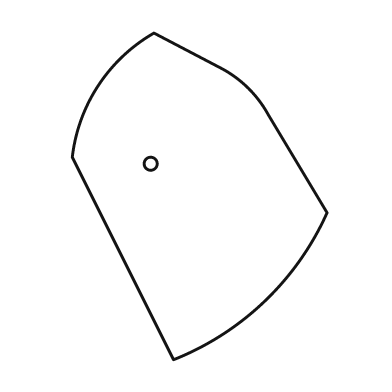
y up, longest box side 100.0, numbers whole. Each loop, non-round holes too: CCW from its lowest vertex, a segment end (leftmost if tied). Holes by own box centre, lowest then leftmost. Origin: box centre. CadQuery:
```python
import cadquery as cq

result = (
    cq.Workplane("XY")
    .moveTo(-8.0, -50.0)
    .threePointArc((20.0, -32.0), (39.0, -5.0))
    .lineTo(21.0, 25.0)
    .threePointArc((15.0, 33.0), (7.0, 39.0))
    .lineTo(-14.0, 50.0)
    .threePointArc((-31.0, 34.0), (-39.0, 12.0))
    .close()
    .moveTo(-15.0, 10.0)
    .circle(2.0)
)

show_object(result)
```